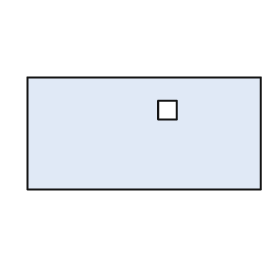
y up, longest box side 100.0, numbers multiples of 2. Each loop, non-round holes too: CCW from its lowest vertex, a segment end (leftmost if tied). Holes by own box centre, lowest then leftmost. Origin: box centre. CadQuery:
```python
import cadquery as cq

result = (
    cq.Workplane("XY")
    .moveTo(-50.0, -24.0)
    .lineTo(50.0, -24.0)
    .lineTo(50.0, 24.0)
    .lineTo(-50.0, 24.0)
    .close()
    .moveTo(6.0, 6.0)
    .lineTo(14.0, 6.0)
    .lineTo(14.0, 14.0)
    .lineTo(6.0, 14.0)
    .close()
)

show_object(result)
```